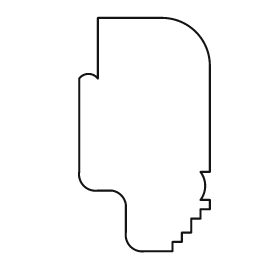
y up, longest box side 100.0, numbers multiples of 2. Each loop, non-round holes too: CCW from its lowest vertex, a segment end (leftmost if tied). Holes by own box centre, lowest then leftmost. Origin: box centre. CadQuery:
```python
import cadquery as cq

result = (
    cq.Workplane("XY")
    .moveTo(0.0, -50.0)
    .lineTo(12.0, -50.0)
    .lineTo(12.0, -46.0)
    .lineTo(16.0, -46.0)
    .lineTo(16.0, -42.0)
    .lineTo(20.0, -42.0)
    .lineTo(20.0, -36.0)
    .lineTo(24.0, -36.0)
    .lineTo(24.0, -32.0)
    .lineTo(28.0, -32.0)
    .lineTo(28.0, -28.0)
    .lineTo(24.0, -28.0)
    .threePointArc((26.0, -22.0), (24.0, -16.0))
    .lineTo(28.0, -16.0)
    .lineTo(28.0, 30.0)
    .threePointArc((22.0, 44.0), (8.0, 50.0))
    .lineTo(-20.0, 50.0)
    .lineTo(-20.0, 24.0)
    .threePointArc((-24.0, 26.0), (-28.0, 24.0))
    .lineTo(-28.0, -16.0)
    .threePointArc((-26.0, -22.0), (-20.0, -24.0))
    .lineTo(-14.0, -24.0)
    .threePointArc((-10.0, -26.0), (-8.0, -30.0))
    .lineTo(-8.0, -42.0)
    .threePointArc((-6.0, -48.0), (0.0, -50.0))
    .close()
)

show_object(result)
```